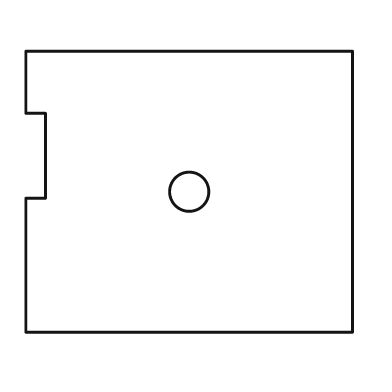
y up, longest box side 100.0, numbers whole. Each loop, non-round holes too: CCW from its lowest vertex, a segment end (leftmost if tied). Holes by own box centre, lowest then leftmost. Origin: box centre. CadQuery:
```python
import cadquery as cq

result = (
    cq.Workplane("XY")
    .moveTo(-50.0, -43.0)
    .lineTo(50.0, -43.0)
    .lineTo(50.0, 43.0)
    .lineTo(-50.0, 43.0)
    .lineTo(-50.0, 24.0)
    .lineTo(-44.0, 24.0)
    .lineTo(-44.0, -2.0)
    .lineTo(-50.0, -2.0)
    .close()
    .moveTo(0.0, 0.0)
    .circle(6.0)
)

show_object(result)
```